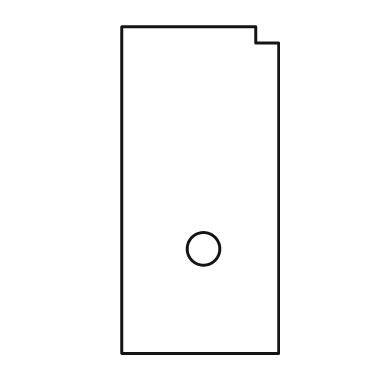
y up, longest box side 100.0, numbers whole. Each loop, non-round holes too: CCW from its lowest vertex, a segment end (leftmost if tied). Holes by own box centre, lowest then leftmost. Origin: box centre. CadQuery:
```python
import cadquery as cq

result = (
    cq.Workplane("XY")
    .moveTo(-24.0, -50.0)
    .lineTo(24.0, -50.0)
    .lineTo(24.0, 45.0)
    .lineTo(17.0, 45.0)
    .lineTo(17.0, 50.0)
    .lineTo(-24.0, 50.0)
    .close()
    .moveTo(1.0, -18.0)
    .circle(5.0)
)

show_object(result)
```